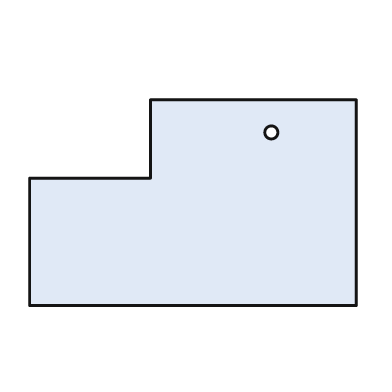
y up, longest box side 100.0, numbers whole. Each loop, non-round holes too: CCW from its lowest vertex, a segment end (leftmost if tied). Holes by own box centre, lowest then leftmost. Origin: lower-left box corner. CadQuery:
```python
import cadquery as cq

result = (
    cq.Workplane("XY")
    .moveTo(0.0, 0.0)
    .lineTo(100.0, 0.0)
    .lineTo(100.0, 63.0)
    .lineTo(37.0, 63.0)
    .lineTo(37.0, 39.0)
    .lineTo(0.0, 39.0)
    .close()
    .moveTo(74.0, 53.0)
    .circle(2.0)
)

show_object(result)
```